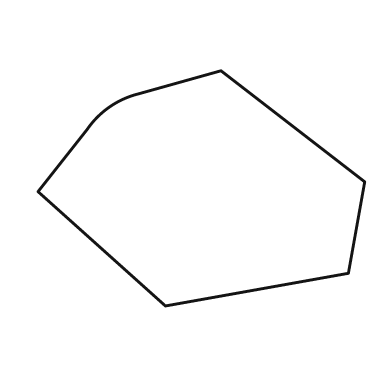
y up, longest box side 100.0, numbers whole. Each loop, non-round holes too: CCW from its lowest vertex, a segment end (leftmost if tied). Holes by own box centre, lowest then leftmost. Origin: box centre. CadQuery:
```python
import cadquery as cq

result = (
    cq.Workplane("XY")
    .moveTo(-11.0, -36.0)
    .lineTo(45.0, -26.0)
    .lineTo(50.0, 2.0)
    .lineTo(6.0, 36.0)
    .lineTo(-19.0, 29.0)
    .threePointArc((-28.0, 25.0), (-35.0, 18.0))
    .lineTo(-50.0, -1.0)
    .close()
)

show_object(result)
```